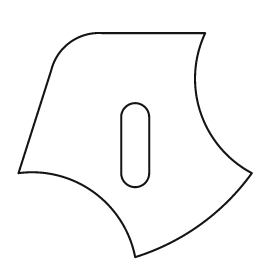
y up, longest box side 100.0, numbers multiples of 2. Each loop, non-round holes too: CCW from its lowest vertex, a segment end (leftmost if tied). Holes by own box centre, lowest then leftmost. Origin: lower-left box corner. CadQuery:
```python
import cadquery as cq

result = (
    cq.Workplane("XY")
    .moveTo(50.0, 0.0)
    .threePointArc((78.0, 14.0), (100.0, 36.0))
    .threePointArc((78.0, 62.0), (80.0, 96.0))
    .lineTo(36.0, 96.0)
    .threePointArc((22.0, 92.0), (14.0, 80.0))
    .lineTo(0.0, 36.0)
    .threePointArc((32.0, 28.0), (50.0, 0.0))
    .close()
    .moveTo(44.0, 36.0)
    .threePointArc((50.0, 30.0), (56.0, 36.0))
    .lineTo(56.0, 60.0)
    .threePointArc((50.0, 66.0), (44.0, 60.0))
    .close()
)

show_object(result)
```